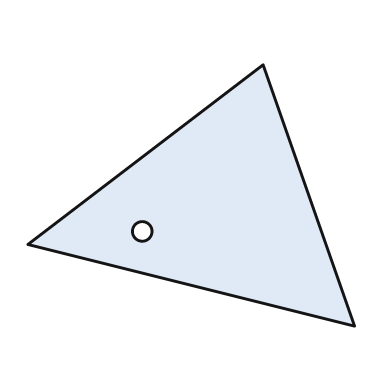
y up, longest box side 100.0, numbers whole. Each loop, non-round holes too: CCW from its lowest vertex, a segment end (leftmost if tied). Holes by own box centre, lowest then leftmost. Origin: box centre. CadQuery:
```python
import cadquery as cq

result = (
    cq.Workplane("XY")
    .moveTo(50.0, -40.0)
    .lineTo(22.0, 40.0)
    .lineTo(-50.0, -15.0)
    .close()
    .moveTo(-15.0, -11.0)
    .circle(3.0)
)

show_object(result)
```